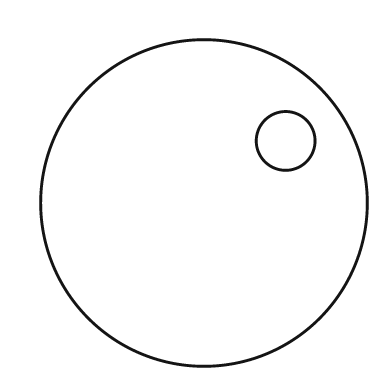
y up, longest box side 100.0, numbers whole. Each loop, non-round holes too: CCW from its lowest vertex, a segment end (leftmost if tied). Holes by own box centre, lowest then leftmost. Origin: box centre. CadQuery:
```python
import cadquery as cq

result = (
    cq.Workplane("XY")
    .moveTo(0.0, 0.0)
    .circle(50.0)
    .moveTo(25.0, 19.0)
    .circle(9.0)
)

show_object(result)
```